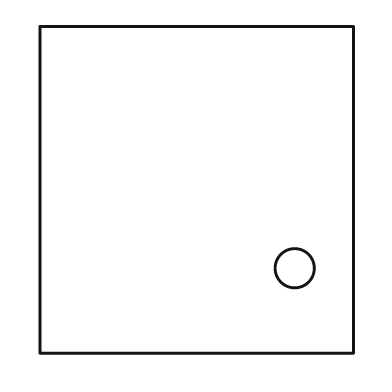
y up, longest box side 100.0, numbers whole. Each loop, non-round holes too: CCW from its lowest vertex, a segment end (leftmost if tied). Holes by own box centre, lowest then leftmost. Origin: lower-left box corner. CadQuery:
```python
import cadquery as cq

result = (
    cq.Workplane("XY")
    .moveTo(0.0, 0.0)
    .lineTo(96.0, 0.0)
    .lineTo(96.0, 100.0)
    .lineTo(0.0, 100.0)
    .close()
    .moveTo(78.0, 26.0)
    .circle(6.0)
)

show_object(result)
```